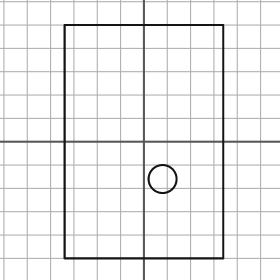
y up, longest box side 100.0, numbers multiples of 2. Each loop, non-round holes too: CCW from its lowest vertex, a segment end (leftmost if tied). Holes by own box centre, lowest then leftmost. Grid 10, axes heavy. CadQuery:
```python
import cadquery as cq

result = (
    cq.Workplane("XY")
    .moveTo(-34.0, -50.0)
    .lineTo(34.0, -50.0)
    .lineTo(34.0, 50.0)
    .lineTo(-34.0, 50.0)
    .close()
    .moveTo(8.0, -16.0)
    .circle(6.0)
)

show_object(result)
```